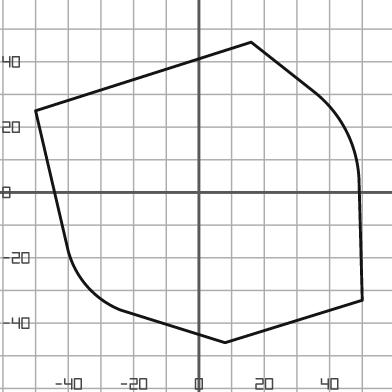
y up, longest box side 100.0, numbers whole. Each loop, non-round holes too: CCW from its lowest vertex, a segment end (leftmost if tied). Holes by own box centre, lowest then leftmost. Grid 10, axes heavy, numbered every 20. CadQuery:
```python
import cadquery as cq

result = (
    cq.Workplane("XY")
    .moveTo(8.0, -46.0)
    .lineTo(50.0, -33.0)
    .lineTo(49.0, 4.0)
    .threePointArc((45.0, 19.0), (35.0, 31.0))
    .lineTo(16.0, 46.0)
    .lineTo(-50.0, 25.0)
    .lineTo(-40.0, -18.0)
    .threePointArc((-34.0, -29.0), (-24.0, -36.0))
    .close()
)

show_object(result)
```